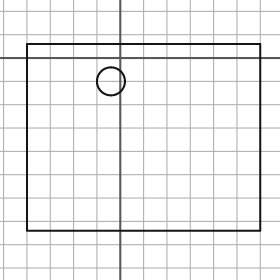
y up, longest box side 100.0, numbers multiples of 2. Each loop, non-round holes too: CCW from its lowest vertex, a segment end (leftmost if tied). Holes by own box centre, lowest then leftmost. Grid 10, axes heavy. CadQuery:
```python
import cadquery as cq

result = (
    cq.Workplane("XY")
    .moveTo(-40.0, -74.0)
    .lineTo(60.0, -74.0)
    .lineTo(60.0, 6.0)
    .lineTo(-40.0, 6.0)
    .close()
    .moveTo(-4.0, -10.0)
    .circle(6.0)
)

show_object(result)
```